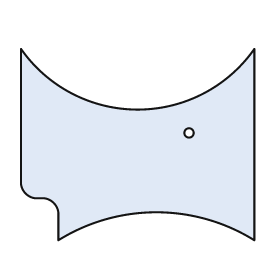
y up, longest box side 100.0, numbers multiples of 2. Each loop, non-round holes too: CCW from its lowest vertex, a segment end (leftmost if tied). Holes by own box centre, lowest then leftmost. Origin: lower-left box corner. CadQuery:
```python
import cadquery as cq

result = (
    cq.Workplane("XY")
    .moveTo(16.0, 0.0)
    .threePointArc((58.0, 12.0), (100.0, 0.0))
    .lineTo(100.0, 82.0)
    .threePointArc((50.0, 56.0), (0.0, 82.0))
    .lineTo(0.0, 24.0)
    .threePointArc((2.0, 20.0), (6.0, 18.0))
    .lineTo(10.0, 18.0)
    .threePointArc((14.0, 16.0), (16.0, 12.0))
    .close()
    .moveTo(72.0, 46.0)
    .circle(2.0)
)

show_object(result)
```